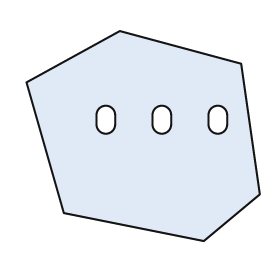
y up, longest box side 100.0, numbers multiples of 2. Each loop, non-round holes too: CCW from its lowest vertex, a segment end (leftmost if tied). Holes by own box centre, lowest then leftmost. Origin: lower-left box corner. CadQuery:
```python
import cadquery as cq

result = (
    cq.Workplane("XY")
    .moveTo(76.0, 0.0)
    .lineTo(100.0, 20.0)
    .lineTo(92.0, 76.0)
    .lineTo(40.0, 90.0)
    .lineTo(0.0, 68.0)
    .lineTo(16.0, 12.0)
    .close()
    .moveTo(30.0, 50.0)
    .threePointArc((34.0, 46.0), (38.0, 50.0))
    .lineTo(38.0, 54.0)
    .threePointArc((34.0, 58.0), (30.0, 54.0))
    .close()
    .moveTo(54.0, 50.0)
    .threePointArc((58.0, 46.0), (62.0, 50.0))
    .lineTo(62.0, 54.0)
    .threePointArc((58.0, 58.0), (54.0, 54.0))
    .close()
    .moveTo(78.0, 50.0)
    .threePointArc((82.0, 46.0), (86.0, 50.0))
    .lineTo(86.0, 54.0)
    .threePointArc((82.0, 58.0), (78.0, 54.0))
    .close()
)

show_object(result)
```